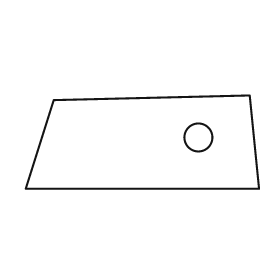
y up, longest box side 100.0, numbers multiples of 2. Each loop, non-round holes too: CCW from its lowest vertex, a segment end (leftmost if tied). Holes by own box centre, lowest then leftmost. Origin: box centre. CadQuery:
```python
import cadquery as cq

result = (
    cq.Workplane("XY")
    .moveTo(-50.0, -20.0)
    .lineTo(50.0, -20.0)
    .lineTo(46.0, 20.0)
    .lineTo(-38.0, 18.0)
    .close()
    .moveTo(24.0, 2.0)
    .circle(6.0)
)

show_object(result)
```